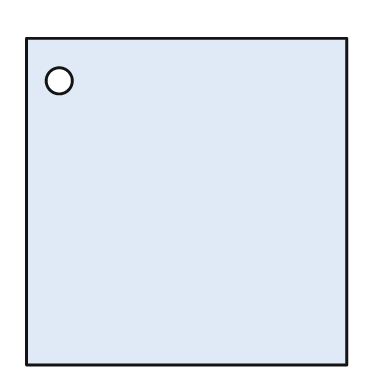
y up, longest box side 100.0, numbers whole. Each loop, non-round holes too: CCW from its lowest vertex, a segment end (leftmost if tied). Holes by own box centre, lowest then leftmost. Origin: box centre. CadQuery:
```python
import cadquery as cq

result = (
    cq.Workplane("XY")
    .moveTo(-49.0, -50.0)
    .lineTo(49.0, -50.0)
    .lineTo(49.0, 50.0)
    .lineTo(-49.0, 50.0)
    .close()
    .moveTo(-39.0, 37.0)
    .circle(4.0)
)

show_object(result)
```